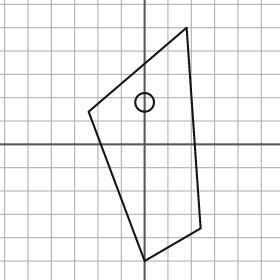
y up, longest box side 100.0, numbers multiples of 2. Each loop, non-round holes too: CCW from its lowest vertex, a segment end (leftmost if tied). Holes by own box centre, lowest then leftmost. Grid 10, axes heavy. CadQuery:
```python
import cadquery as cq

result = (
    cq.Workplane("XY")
    .moveTo(0.0, -50.0)
    .lineTo(24.0, -36.0)
    .lineTo(18.0, 50.0)
    .lineTo(-24.0, 14.0)
    .close()
    .moveTo(0.0, 18.0)
    .circle(4.0)
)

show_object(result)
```